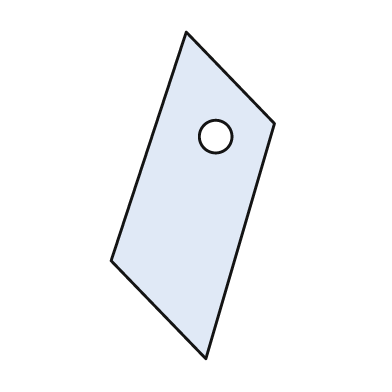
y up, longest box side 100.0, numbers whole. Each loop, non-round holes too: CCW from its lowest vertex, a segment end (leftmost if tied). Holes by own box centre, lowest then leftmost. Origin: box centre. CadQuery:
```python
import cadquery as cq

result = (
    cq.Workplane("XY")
    .moveTo(4.0, -50.0)
    .lineTo(25.0, 22.0)
    .lineTo(-2.0, 50.0)
    .lineTo(-25.0, -20.0)
    .close()
    .moveTo(7.0, 18.0)
    .circle(5.0)
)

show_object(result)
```